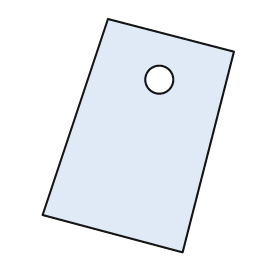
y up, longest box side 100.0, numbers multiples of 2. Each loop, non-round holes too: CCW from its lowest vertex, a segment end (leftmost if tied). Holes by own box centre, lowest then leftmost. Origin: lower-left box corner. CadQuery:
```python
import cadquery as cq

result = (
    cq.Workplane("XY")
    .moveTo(60.0, 0.0)
    .lineTo(82.0, 86.0)
    .lineTo(28.0, 100.0)
    .lineTo(0.0, 16.0)
    .close()
    .moveTo(50.0, 74.0)
    .circle(6.0)
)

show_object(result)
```